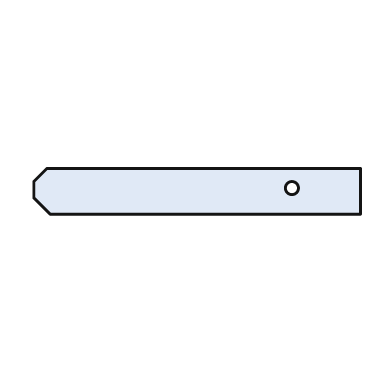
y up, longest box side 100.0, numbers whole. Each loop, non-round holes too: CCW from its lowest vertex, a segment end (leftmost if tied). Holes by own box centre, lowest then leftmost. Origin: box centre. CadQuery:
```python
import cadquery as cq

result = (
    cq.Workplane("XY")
    .moveTo(-45.0, -7.0)
    .lineTo(50.0, -7.0)
    .lineTo(50.0, 7.0)
    .lineTo(-46.0, 7.0)
    .lineTo(-50.0, 3.0)
    .lineTo(-50.0, -2.0)
    .close()
    .moveTo(29.0, 1.0)
    .circle(2.0)
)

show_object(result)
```